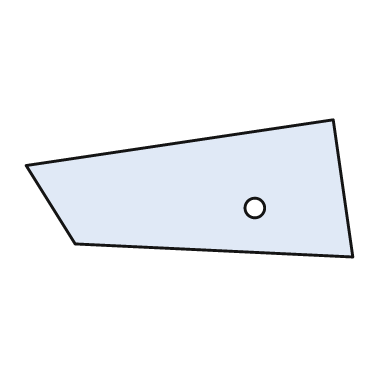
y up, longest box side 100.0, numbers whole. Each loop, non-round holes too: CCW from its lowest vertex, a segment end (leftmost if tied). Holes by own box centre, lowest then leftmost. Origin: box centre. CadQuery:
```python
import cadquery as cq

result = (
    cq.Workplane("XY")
    .moveTo(50.0, -21.0)
    .lineTo(44.0, 21.0)
    .lineTo(-50.0, 7.0)
    .lineTo(-35.0, -17.0)
    .close()
    .moveTo(20.0, -6.0)
    .circle(3.0)
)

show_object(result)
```